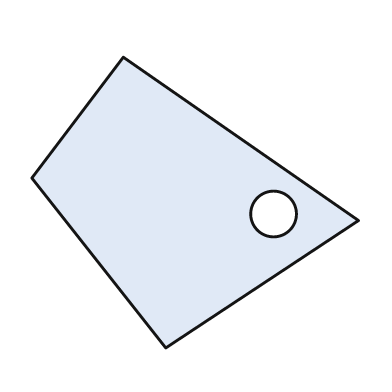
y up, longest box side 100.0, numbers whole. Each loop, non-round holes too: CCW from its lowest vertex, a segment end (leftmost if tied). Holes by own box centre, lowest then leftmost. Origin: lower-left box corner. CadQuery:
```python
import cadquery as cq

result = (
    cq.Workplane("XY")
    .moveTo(41.0, 0.0)
    .lineTo(100.0, 39.0)
    .lineTo(28.0, 89.0)
    .lineTo(0.0, 52.0)
    .close()
    .moveTo(74.0, 41.0)
    .circle(7.0)
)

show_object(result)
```